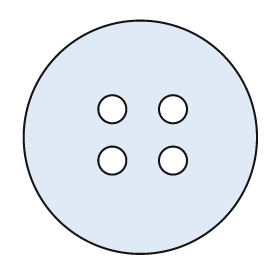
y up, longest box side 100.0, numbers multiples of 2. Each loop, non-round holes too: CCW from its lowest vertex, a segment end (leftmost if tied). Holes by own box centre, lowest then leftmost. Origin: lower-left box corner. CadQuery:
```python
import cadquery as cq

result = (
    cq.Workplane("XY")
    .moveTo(50.0, 50.0)
    .circle(50.0)
    .moveTo(38.0, 40.0)
    .circle(6.0)
    .moveTo(64.0, 40.0)
    .circle(6.0)
    .moveTo(38.0, 62.0)
    .circle(6.0)
    .moveTo(64.0, 62.0)
    .circle(6.0)
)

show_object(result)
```